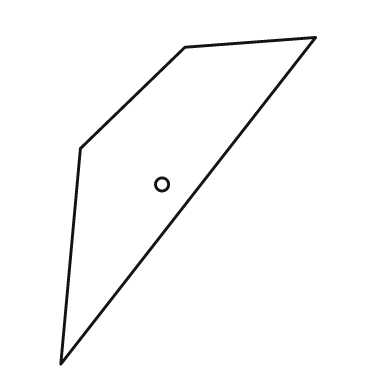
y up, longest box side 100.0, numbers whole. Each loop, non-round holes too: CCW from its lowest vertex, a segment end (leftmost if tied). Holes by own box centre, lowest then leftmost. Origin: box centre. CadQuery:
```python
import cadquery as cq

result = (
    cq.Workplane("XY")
    .moveTo(-39.0, -50.0)
    .lineTo(39.0, 50.0)
    .lineTo(-1.0, 47.0)
    .lineTo(-33.0, 16.0)
    .close()
    .moveTo(-8.0, 5.0)
    .circle(2.0)
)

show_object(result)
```